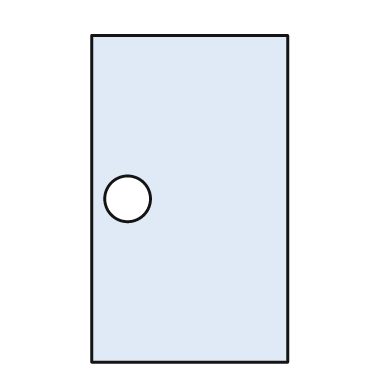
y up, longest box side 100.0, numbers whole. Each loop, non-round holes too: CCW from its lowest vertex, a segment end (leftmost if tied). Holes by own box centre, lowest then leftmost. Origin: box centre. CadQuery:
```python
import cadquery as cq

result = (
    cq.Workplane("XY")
    .moveTo(-30.0, -50.0)
    .lineTo(30.0, -50.0)
    .lineTo(30.0, 50.0)
    .lineTo(-30.0, 50.0)
    .close()
    .moveTo(-19.0, 0.0)
    .circle(7.0)
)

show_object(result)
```